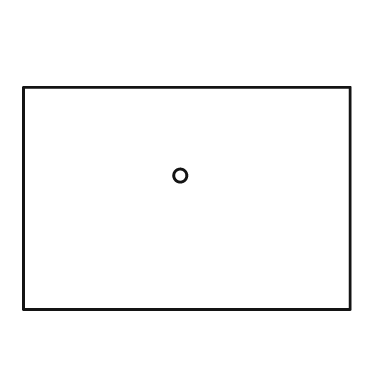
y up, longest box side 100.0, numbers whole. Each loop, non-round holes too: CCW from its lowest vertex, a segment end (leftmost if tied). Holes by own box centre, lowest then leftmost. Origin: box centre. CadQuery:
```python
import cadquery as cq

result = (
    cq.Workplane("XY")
    .moveTo(-50.0, -34.0)
    .lineTo(50.0, -34.0)
    .lineTo(50.0, 34.0)
    .lineTo(-50.0, 34.0)
    .close()
    .moveTo(-2.0, 7.0)
    .circle(2.0)
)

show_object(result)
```